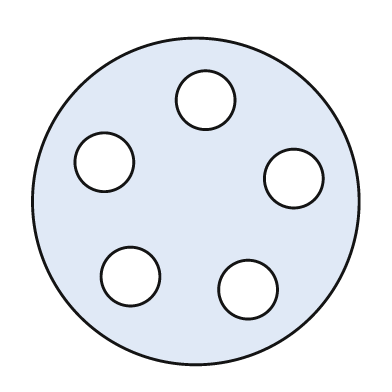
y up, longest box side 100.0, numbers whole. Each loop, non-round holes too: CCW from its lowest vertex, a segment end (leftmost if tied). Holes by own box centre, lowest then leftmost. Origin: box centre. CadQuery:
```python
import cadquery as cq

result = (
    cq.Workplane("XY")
    .moveTo(0.0, 0.0)
    .circle(50.0)
    .moveTo(16.0, -27.0)
    .circle(9.0)
    .moveTo(-20.0, -23.0)
    .circle(9.0)
    .moveTo(30.0, 7.0)
    .circle(9.0)
    .moveTo(-28.0, 12.0)
    .circle(9.0)
    .moveTo(3.0, 31.0)
    .circle(9.0)
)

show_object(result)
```